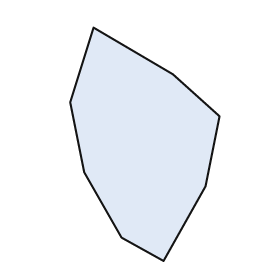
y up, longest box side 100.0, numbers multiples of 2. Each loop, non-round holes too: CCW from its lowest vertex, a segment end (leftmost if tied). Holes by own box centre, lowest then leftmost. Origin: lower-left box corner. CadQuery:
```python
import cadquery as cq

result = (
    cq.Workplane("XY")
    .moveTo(40.0, 0.0)
    .lineTo(58.0, 32.0)
    .lineTo(64.0, 62.0)
    .lineTo(44.0, 80.0)
    .lineTo(10.0, 100.0)
    .lineTo(0.0, 68.0)
    .lineTo(6.0, 38.0)
    .lineTo(22.0, 10.0)
    .close()
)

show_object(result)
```